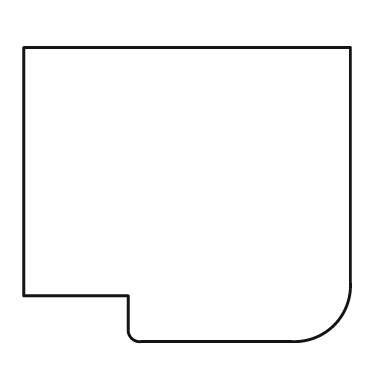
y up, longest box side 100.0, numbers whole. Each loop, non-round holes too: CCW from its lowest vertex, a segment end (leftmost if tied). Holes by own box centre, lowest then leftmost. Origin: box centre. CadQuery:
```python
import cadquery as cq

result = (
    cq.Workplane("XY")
    .moveTo(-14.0, -45.0)
    .lineTo(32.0, -45.0)
    .threePointArc((45.0, -40.0), (50.0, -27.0))
    .lineTo(50.0, 45.0)
    .lineTo(-50.0, 45.0)
    .lineTo(-50.0, -31.0)
    .lineTo(-18.0, -31.0)
    .lineTo(-18.0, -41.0)
    .threePointArc((-17.0, -44.0), (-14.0, -45.0))
    .close()
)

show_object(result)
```